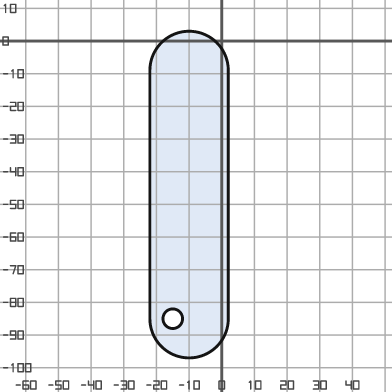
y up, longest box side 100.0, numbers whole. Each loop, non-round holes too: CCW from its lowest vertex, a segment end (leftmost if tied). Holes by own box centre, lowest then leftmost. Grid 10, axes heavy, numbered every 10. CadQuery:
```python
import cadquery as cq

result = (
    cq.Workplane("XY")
    .moveTo(-22.0, -85.0)
    .threePointArc((-10.0, -97.0), (2.0, -85.0))
    .lineTo(2.0, -9.0)
    .threePointArc((-10.0, 3.0), (-22.0, -9.0))
    .close()
    .moveTo(-15.0, -85.0)
    .circle(3.0)
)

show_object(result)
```